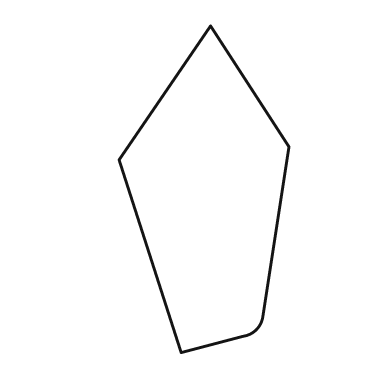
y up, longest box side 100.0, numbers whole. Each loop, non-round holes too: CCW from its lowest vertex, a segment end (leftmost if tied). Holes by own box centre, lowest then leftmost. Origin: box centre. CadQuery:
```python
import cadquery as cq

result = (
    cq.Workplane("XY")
    .moveTo(-7.0, -50.0)
    .lineTo(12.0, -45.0)
    .threePointArc((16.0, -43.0), (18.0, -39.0))
    .lineTo(26.0, 13.0)
    .lineTo(2.0, 50.0)
    .lineTo(-26.0, 9.0)
    .close()
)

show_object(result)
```